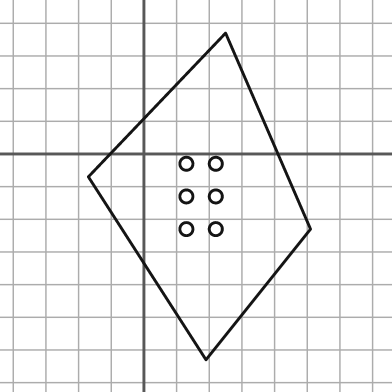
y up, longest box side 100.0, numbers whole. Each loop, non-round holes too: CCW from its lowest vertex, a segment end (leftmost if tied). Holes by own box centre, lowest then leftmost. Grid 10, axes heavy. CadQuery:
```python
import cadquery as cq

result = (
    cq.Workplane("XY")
    .moveTo(19.0, -63.0)
    .lineTo(51.0, -23.0)
    .lineTo(25.0, 37.0)
    .lineTo(-17.0, -7.0)
    .close()
    .moveTo(13.0, -23.0)
    .circle(2.0)
    .moveTo(22.0, -23.0)
    .circle(2.0)
    .moveTo(13.0, -13.0)
    .circle(2.0)
    .moveTo(22.0, -13.0)
    .circle(2.0)
    .moveTo(13.0, -3.0)
    .circle(2.0)
    .moveTo(22.0, -3.0)
    .circle(2.0)
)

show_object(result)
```